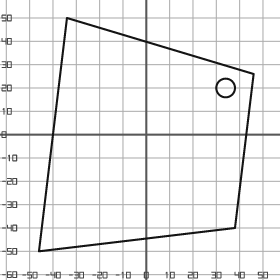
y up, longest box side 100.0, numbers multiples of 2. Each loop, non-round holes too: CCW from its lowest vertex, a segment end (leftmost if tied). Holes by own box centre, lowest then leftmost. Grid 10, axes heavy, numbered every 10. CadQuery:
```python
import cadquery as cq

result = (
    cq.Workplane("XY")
    .moveTo(-46.0, -50.0)
    .lineTo(38.0, -40.0)
    .lineTo(46.0, 26.0)
    .lineTo(-34.0, 50.0)
    .close()
    .moveTo(34.0, 20.0)
    .circle(4.0)
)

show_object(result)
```